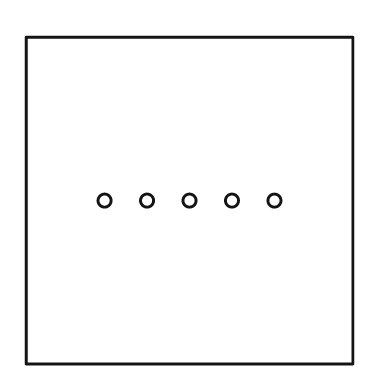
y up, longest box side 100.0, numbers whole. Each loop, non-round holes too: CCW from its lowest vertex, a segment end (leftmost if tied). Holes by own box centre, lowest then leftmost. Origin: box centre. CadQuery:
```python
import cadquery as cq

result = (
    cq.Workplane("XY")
    .moveTo(-50.0, -50.0)
    .lineTo(50.0, -50.0)
    .lineTo(50.0, 50.0)
    .lineTo(-50.0, 50.0)
    .close()
    .moveTo(-26.0, 0.0)
    .circle(2.0)
    .moveTo(-13.0, 0.0)
    .circle(2.0)
    .moveTo(0.0, 0.0)
    .circle(2.0)
    .moveTo(13.0, 0.0)
    .circle(2.0)
    .moveTo(26.0, 0.0)
    .circle(2.0)
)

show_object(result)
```